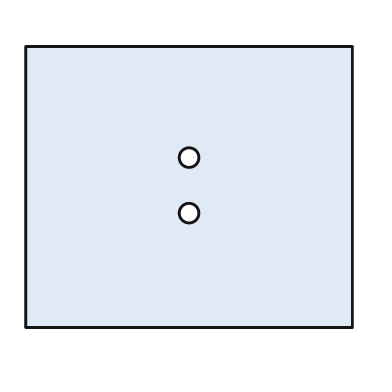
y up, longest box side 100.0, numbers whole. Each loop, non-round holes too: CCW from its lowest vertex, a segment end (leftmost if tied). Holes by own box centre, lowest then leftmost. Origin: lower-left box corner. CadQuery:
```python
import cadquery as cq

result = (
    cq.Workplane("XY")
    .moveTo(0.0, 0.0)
    .lineTo(100.0, 0.0)
    .lineTo(100.0, 86.0)
    .lineTo(0.0, 86.0)
    .close()
    .moveTo(50.0, 35.0)
    .circle(3.0)
    .moveTo(50.0, 52.0)
    .circle(3.0)
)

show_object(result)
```